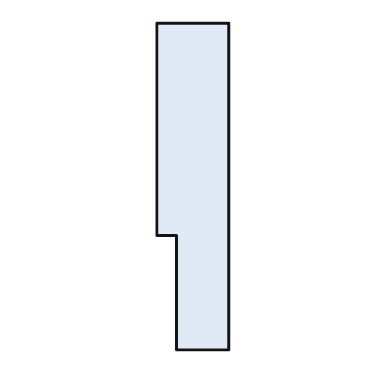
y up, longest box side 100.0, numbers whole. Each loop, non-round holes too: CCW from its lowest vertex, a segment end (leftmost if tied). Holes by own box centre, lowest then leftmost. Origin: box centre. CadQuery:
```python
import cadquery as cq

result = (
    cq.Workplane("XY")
    .moveTo(-5.0, -50.0)
    .lineTo(11.0, -50.0)
    .lineTo(11.0, 50.0)
    .lineTo(-11.0, 50.0)
    .lineTo(-11.0, -15.0)
    .lineTo(-5.0, -15.0)
    .close()
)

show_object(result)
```